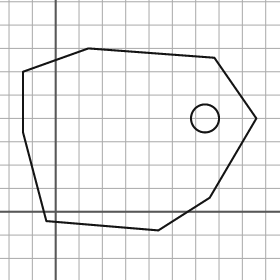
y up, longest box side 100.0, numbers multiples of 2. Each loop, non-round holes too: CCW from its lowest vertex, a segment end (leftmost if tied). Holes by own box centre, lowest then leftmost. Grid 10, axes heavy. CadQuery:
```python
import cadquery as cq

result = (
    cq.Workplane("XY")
    .moveTo(44.0, -8.0)
    .lineTo(66.0, 6.0)
    .lineTo(86.0, 40.0)
    .lineTo(68.0, 66.0)
    .lineTo(14.0, 70.0)
    .lineTo(-14.0, 60.0)
    .lineTo(-14.0, 34.0)
    .lineTo(-4.0, -4.0)
    .close()
    .moveTo(64.0, 40.0)
    .circle(6.0)
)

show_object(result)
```